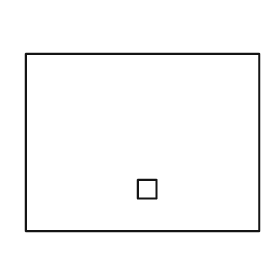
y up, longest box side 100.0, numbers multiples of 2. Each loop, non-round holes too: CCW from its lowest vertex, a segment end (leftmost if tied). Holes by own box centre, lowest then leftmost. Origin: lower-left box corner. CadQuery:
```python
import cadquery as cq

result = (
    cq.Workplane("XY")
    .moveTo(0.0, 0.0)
    .lineTo(100.0, 0.0)
    .lineTo(100.0, 76.0)
    .lineTo(0.0, 76.0)
    .close()
    .moveTo(48.0, 14.0)
    .lineTo(56.0, 14.0)
    .lineTo(56.0, 22.0)
    .lineTo(48.0, 22.0)
    .close()
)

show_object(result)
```